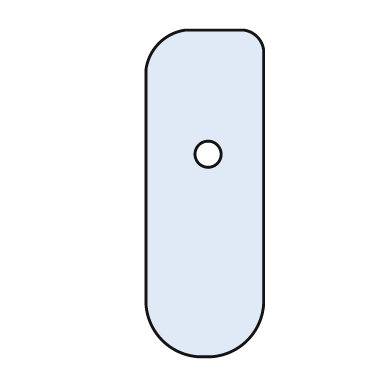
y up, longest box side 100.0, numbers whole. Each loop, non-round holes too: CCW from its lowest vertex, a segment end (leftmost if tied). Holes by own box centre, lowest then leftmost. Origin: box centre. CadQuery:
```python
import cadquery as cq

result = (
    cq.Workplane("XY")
    .moveTo(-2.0, -50.0)
    .lineTo(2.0, -50.0)
    .threePointArc((13.0, -45.0), (18.0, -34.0))
    .lineTo(18.0, 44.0)
    .threePointArc((16.0, 48.0), (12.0, 50.0))
    .lineTo(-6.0, 50.0)
    .threePointArc((-14.0, 46.0), (-18.0, 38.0))
    .lineTo(-18.0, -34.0)
    .threePointArc((-13.0, -45.0), (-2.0, -50.0))
    .close()
    .moveTo(1.0, 12.0)
    .circle(4.0)
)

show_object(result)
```